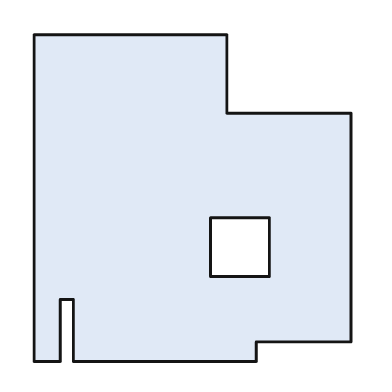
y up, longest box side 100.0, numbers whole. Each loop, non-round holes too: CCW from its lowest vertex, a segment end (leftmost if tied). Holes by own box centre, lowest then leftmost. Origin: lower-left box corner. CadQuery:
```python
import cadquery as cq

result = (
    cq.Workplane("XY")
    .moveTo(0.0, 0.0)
    .lineTo(8.0, 0.0)
    .lineTo(8.0, 19.0)
    .lineTo(12.0, 19.0)
    .lineTo(12.0, 0.0)
    .lineTo(68.0, 0.0)
    .lineTo(68.0, 6.0)
    .lineTo(97.0, 6.0)
    .lineTo(97.0, 76.0)
    .lineTo(59.0, 76.0)
    .lineTo(59.0, 100.0)
    .lineTo(0.0, 100.0)
    .close()
    .moveTo(54.0, 26.0)
    .lineTo(72.0, 26.0)
    .lineTo(72.0, 44.0)
    .lineTo(54.0, 44.0)
    .close()
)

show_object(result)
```